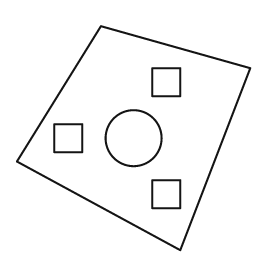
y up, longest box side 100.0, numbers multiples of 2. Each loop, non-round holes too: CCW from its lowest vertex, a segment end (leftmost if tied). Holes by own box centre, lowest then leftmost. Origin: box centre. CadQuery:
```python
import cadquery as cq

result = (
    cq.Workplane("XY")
    .moveTo(20.0, -48.0)
    .lineTo(50.0, 30.0)
    .lineTo(-14.0, 48.0)
    .lineTo(-50.0, -10.0)
    .close()
    .moveTo(8.0, -30.0)
    .lineTo(20.0, -30.0)
    .lineTo(20.0, -18.0)
    .lineTo(8.0, -18.0)
    .close()
    .moveTo(-34.0, -6.0)
    .lineTo(-22.0, -6.0)
    .lineTo(-22.0, 6.0)
    .lineTo(-34.0, 6.0)
    .close()
    .moveTo(0.0, 0.0)
    .circle(12.0)
    .moveTo(8.0, 18.0)
    .lineTo(20.0, 18.0)
    .lineTo(20.0, 30.0)
    .lineTo(8.0, 30.0)
    .close()
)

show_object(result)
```